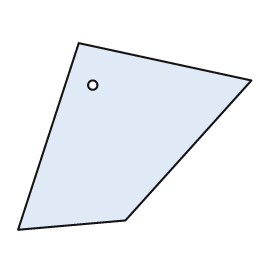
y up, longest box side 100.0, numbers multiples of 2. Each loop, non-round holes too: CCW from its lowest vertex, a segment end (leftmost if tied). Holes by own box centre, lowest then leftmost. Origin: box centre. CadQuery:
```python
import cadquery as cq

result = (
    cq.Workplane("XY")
    .moveTo(-50.0, -40.0)
    .lineTo(-4.0, -36.0)
    .lineTo(50.0, 24.0)
    .lineTo(-24.0, 40.0)
    .close()
    .moveTo(-18.0, 22.0)
    .circle(2.0)
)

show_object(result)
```